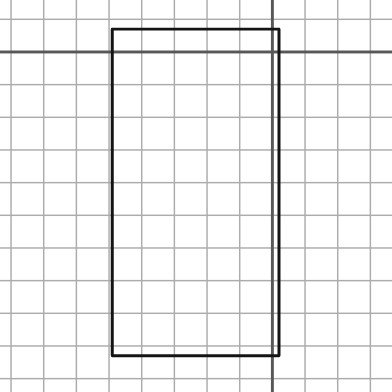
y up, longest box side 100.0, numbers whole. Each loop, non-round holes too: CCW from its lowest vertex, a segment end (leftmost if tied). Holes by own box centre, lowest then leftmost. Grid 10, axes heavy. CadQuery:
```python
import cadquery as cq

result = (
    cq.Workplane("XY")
    .moveTo(-49.0, -93.0)
    .lineTo(2.0, -93.0)
    .lineTo(2.0, 7.0)
    .lineTo(-49.0, 7.0)
    .close()
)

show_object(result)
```